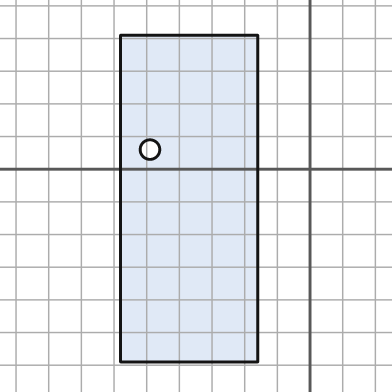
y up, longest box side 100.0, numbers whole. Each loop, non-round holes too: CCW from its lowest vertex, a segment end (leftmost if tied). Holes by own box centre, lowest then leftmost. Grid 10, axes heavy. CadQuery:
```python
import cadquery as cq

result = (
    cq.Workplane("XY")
    .moveTo(-58.0, -59.0)
    .lineTo(-16.0, -59.0)
    .lineTo(-16.0, 41.0)
    .lineTo(-58.0, 41.0)
    .close()
    .moveTo(-49.0, 6.0)
    .circle(3.0)
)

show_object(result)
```